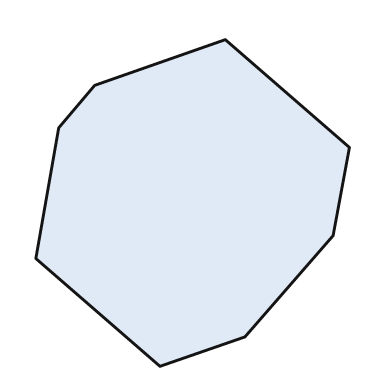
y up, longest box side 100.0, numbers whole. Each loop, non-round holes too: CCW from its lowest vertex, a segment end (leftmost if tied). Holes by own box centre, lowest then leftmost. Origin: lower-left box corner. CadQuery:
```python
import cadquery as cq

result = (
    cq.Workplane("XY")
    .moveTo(38.0, 0.0)
    .lineTo(64.0, 9.0)
    .lineTo(91.0, 40.0)
    .lineTo(96.0, 67.0)
    .lineTo(58.0, 100.0)
    .lineTo(18.0, 86.0)
    .lineTo(7.0, 73.0)
    .lineTo(0.0, 33.0)
    .close()
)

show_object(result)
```